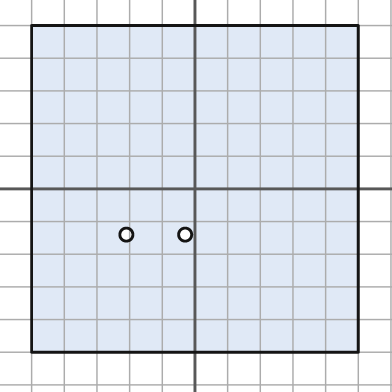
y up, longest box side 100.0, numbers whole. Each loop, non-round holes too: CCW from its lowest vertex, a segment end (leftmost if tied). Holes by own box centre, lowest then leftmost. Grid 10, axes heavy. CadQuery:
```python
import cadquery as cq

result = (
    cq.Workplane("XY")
    .moveTo(-50.0, -50.0)
    .lineTo(50.0, -50.0)
    .lineTo(50.0, 50.0)
    .lineTo(-50.0, 50.0)
    .close()
    .moveTo(-21.0, -14.0)
    .circle(2.0)
    .moveTo(-3.0, -14.0)
    .circle(2.0)
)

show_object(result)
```